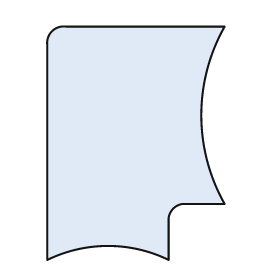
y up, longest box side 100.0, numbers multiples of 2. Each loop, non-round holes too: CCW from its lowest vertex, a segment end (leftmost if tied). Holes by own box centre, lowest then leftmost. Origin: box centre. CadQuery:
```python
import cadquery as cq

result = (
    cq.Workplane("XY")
    .moveTo(-38.0, -50.0)
    .threePointArc((-12.0, -44.0), (14.0, -50.0))
    .lineTo(14.0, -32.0)
    .threePointArc((16.0, -28.0), (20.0, -26.0))
    .lineTo(38.0, -26.0)
    .threePointArc((28.0, 12.0), (38.0, 50.0))
    .lineTo(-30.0, 50.0)
    .threePointArc((-36.0, 48.0), (-38.0, 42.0))
    .close()
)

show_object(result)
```